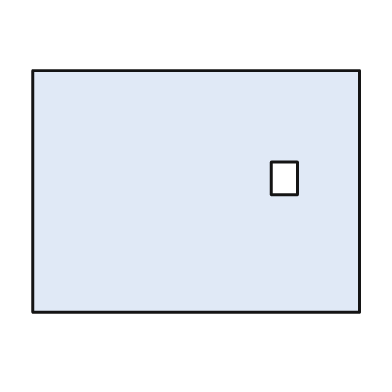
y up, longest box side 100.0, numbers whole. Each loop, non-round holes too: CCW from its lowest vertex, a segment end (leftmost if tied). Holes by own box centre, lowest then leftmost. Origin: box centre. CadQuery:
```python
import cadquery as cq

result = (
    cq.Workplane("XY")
    .moveTo(-50.0, -37.0)
    .lineTo(50.0, -37.0)
    .lineTo(50.0, 37.0)
    .lineTo(-50.0, 37.0)
    .close()
    .moveTo(23.0, -1.0)
    .lineTo(31.0, -1.0)
    .lineTo(31.0, 9.0)
    .lineTo(23.0, 9.0)
    .close()
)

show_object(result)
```